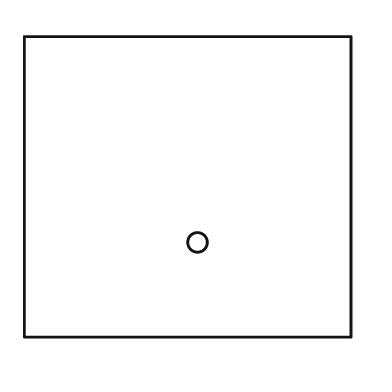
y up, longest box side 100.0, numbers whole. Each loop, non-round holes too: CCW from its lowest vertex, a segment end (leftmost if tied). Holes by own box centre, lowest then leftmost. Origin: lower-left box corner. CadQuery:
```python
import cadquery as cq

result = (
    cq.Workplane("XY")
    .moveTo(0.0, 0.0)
    .lineTo(100.0, 0.0)
    .lineTo(100.0, 92.0)
    .lineTo(0.0, 92.0)
    .close()
    .moveTo(53.0, 29.0)
    .circle(3.0)
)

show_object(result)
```